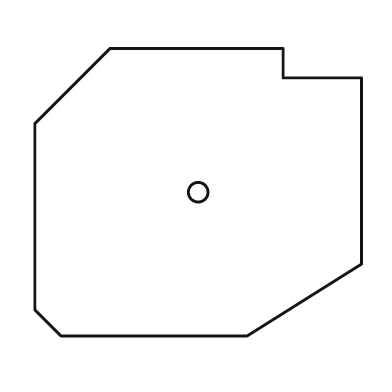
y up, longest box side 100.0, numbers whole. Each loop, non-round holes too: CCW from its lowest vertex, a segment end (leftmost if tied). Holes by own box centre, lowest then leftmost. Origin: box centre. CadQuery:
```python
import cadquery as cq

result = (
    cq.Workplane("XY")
    .moveTo(-42.0, -44.0)
    .lineTo(15.0, -44.0)
    .lineTo(50.0, -22.0)
    .lineTo(50.0, 35.0)
    .lineTo(26.0, 35.0)
    .lineTo(26.0, 44.0)
    .lineTo(-27.0, 44.0)
    .lineTo(-50.0, 21.0)
    .lineTo(-50.0, -36.0)
    .close()
    .moveTo(0.0, 0.0)
    .circle(3.0)
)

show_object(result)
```